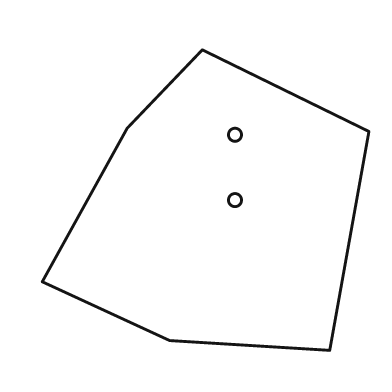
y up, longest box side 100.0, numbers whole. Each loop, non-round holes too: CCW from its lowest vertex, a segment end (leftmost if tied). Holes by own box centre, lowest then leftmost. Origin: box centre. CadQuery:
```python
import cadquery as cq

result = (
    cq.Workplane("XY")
    .moveTo(38.0, -46.0)
    .lineTo(50.0, 21.0)
    .lineTo(-1.0, 46.0)
    .lineTo(-24.0, 22.0)
    .lineTo(-50.0, -25.0)
    .lineTo(-11.0, -43.0)
    .close()
    .moveTo(9.0, 0.0)
    .circle(2.0)
    .moveTo(9.0, 20.0)
    .circle(2.0)
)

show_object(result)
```